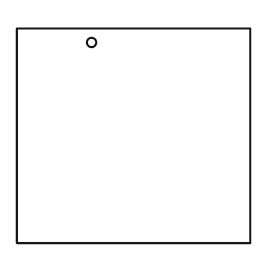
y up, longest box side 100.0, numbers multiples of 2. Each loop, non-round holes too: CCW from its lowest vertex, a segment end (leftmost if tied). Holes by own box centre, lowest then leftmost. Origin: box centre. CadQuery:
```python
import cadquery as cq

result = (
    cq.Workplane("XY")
    .moveTo(-50.0, -46.0)
    .lineTo(50.0, -46.0)
    .lineTo(50.0, 46.0)
    .lineTo(-50.0, 46.0)
    .close()
    .moveTo(-18.0, 40.0)
    .circle(2.0)
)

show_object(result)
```